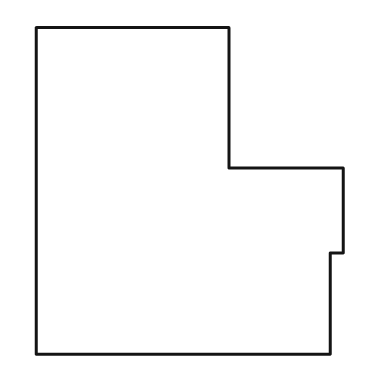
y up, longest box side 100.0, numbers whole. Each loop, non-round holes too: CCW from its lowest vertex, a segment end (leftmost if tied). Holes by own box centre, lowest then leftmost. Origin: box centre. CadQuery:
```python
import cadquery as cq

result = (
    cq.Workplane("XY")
    .moveTo(-47.0, -50.0)
    .lineTo(43.0, -50.0)
    .lineTo(43.0, -19.0)
    .lineTo(47.0, -19.0)
    .lineTo(47.0, 7.0)
    .lineTo(12.0, 7.0)
    .lineTo(12.0, 50.0)
    .lineTo(-47.0, 50.0)
    .close()
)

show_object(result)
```